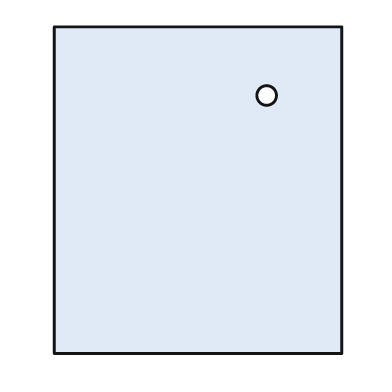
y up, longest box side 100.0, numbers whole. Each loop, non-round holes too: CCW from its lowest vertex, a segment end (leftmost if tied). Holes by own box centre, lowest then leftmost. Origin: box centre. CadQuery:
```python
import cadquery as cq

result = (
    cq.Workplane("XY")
    .moveTo(-44.0, -50.0)
    .lineTo(44.0, -50.0)
    .lineTo(44.0, 50.0)
    .lineTo(-44.0, 50.0)
    .close()
    .moveTo(21.0, 29.0)
    .circle(3.0)
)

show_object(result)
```